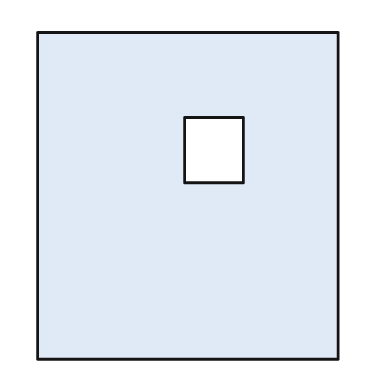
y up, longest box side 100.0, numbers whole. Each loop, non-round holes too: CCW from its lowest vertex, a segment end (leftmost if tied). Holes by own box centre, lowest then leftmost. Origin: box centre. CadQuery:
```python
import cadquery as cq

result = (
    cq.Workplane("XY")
    .moveTo(-46.0, -50.0)
    .lineTo(46.0, -50.0)
    .lineTo(46.0, 50.0)
    .lineTo(-46.0, 50.0)
    .close()
    .moveTo(-1.0, 4.0)
    .lineTo(17.0, 4.0)
    .lineTo(17.0, 24.0)
    .lineTo(-1.0, 24.0)
    .close()
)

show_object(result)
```